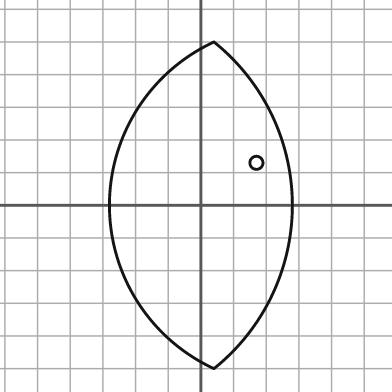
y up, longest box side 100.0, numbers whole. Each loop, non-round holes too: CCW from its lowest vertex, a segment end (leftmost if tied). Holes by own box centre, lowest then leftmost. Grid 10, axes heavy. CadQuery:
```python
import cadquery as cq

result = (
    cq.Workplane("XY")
    .moveTo(4.0, -50.0)
    .threePointArc((28.0, 0.0), (4.0, 50.0))
    .threePointArc((-28.0, 0.0), (4.0, -50.0))
    .close()
    .moveTo(17.0, 13.0)
    .circle(2.0)
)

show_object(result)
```